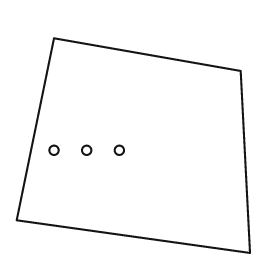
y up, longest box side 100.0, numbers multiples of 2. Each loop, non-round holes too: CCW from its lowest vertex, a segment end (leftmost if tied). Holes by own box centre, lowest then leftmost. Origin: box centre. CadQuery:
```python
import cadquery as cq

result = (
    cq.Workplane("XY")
    .moveTo(50.0, -46.0)
    .lineTo(46.0, 32.0)
    .lineTo(-34.0, 46.0)
    .lineTo(-50.0, -32.0)
    .close()
    .moveTo(-34.0, -2.0)
    .circle(2.0)
    .moveTo(-20.0, -2.0)
    .circle(2.0)
    .moveTo(-6.0, -2.0)
    .circle(2.0)
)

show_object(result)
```